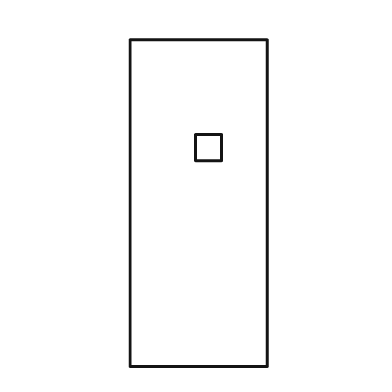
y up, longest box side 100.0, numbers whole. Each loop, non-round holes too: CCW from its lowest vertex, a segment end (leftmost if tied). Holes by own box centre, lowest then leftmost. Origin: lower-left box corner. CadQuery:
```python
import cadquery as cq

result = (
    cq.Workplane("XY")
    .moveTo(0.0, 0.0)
    .lineTo(42.0, 0.0)
    .lineTo(42.0, 100.0)
    .lineTo(0.0, 100.0)
    .close()
    .moveTo(20.0, 63.0)
    .lineTo(28.0, 63.0)
    .lineTo(28.0, 71.0)
    .lineTo(20.0, 71.0)
    .close()
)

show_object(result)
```